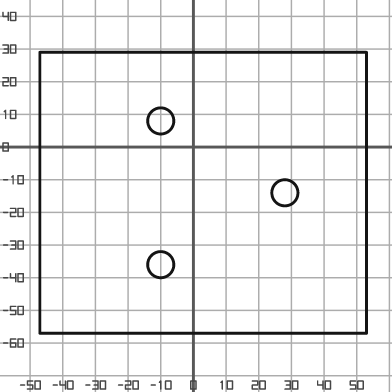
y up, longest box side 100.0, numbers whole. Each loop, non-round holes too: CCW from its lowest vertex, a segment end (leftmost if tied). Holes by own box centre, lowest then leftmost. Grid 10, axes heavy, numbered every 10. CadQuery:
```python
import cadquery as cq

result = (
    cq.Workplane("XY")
    .moveTo(-47.0, -57.0)
    .lineTo(53.0, -57.0)
    .lineTo(53.0, 29.0)
    .lineTo(-47.0, 29.0)
    .close()
    .moveTo(-10.0, -36.0)
    .circle(4.0)
    .moveTo(28.0, -14.0)
    .circle(4.0)
    .moveTo(-10.0, 8.0)
    .circle(4.0)
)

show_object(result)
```